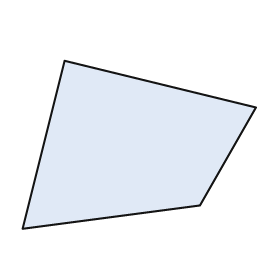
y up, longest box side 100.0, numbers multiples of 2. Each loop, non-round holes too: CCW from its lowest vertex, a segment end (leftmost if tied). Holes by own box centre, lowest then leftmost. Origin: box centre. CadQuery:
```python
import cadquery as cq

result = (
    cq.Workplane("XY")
    .moveTo(-50.0, -36.0)
    .lineTo(26.0, -26.0)
    .lineTo(50.0, 16.0)
    .lineTo(-32.0, 36.0)
    .close()
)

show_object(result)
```